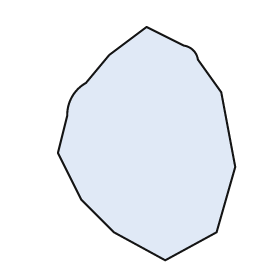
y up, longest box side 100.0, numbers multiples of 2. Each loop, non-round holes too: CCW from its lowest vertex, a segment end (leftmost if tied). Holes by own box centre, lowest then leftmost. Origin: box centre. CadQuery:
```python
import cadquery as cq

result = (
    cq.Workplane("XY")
    .moveTo(8.0, -50.0)
    .lineTo(30.0, -38.0)
    .lineTo(38.0, -10.0)
    .lineTo(32.0, 22.0)
    .lineTo(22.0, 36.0)
    .threePointArc((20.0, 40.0), (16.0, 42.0))
    .lineTo(0.0, 50.0)
    .lineTo(-16.0, 38.0)
    .lineTo(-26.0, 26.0)
    .threePointArc((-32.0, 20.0), (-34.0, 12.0))
    .lineTo(-38.0, -4.0)
    .lineTo(-28.0, -24.0)
    .lineTo(-14.0, -38.0)
    .close()
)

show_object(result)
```